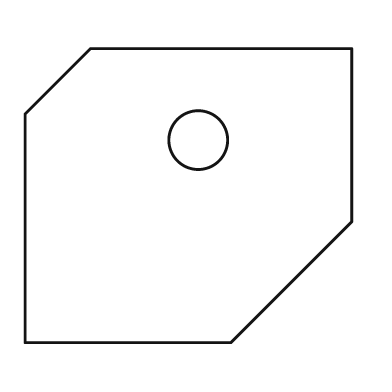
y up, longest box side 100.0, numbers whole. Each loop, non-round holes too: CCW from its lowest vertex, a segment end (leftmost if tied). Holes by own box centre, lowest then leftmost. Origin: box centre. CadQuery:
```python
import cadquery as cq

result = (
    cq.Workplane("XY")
    .moveTo(-50.0, -45.0)
    .lineTo(13.0, -45.0)
    .lineTo(50.0, -8.0)
    .lineTo(50.0, 45.0)
    .lineTo(-30.0, 45.0)
    .lineTo(-50.0, 25.0)
    .close()
    .moveTo(3.0, 17.0)
    .circle(9.0)
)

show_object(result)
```